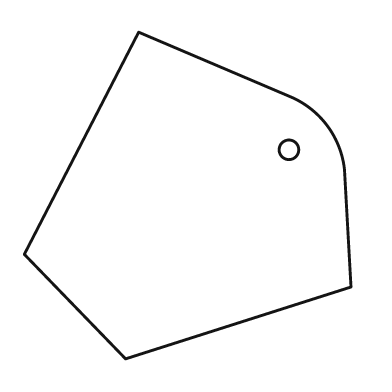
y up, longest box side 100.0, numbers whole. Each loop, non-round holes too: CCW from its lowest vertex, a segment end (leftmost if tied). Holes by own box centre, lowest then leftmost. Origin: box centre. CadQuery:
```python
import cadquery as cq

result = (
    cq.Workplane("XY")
    .moveTo(-19.0, -50.0)
    .lineTo(50.0, -28.0)
    .lineTo(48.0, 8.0)
    .threePointArc((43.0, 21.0), (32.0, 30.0))
    .lineTo(-15.0, 50.0)
    .lineTo(-50.0, -18.0)
    .close()
    .moveTo(31.0, 14.0)
    .circle(3.0)
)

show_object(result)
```